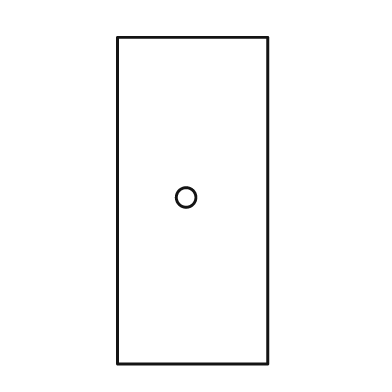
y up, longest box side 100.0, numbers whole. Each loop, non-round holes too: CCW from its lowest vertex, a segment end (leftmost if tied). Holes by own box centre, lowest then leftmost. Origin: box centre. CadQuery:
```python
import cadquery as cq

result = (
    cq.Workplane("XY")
    .moveTo(-23.0, -50.0)
    .lineTo(23.0, -50.0)
    .lineTo(23.0, 50.0)
    .lineTo(-23.0, 50.0)
    .close()
    .moveTo(-2.0, 1.0)
    .circle(3.0)
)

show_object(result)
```